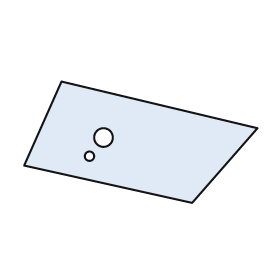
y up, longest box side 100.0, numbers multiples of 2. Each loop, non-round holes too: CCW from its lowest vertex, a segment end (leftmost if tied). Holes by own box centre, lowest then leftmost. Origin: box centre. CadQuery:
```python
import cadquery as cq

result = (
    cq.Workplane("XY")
    .moveTo(22.0, -26.0)
    .lineTo(50.0, 6.0)
    .lineTo(-34.0, 26.0)
    .lineTo(-50.0, -10.0)
    .close()
    .moveTo(-22.0, -6.0)
    .circle(2.0)
    .moveTo(-16.0, 2.0)
    .circle(4.0)
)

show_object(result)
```